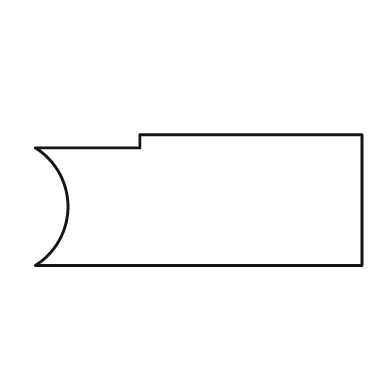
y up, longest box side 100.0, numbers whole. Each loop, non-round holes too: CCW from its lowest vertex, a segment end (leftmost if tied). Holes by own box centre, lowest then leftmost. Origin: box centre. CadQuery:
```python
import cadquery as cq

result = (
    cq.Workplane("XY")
    .moveTo(-50.0, -20.0)
    .lineTo(50.0, -20.0)
    .lineTo(50.0, 20.0)
    .lineTo(-18.0, 20.0)
    .lineTo(-18.0, 16.0)
    .lineTo(-50.0, 16.0)
    .threePointArc((-40.0, -2.0), (-50.0, -20.0))
    .close()
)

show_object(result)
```